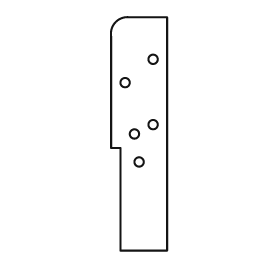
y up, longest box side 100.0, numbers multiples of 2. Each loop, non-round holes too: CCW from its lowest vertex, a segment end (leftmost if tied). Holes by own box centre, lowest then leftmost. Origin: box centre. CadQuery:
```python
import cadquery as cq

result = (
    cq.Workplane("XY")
    .moveTo(-8.0, -50.0)
    .lineTo(12.0, -50.0)
    .lineTo(12.0, 50.0)
    .lineTo(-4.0, 50.0)
    .threePointArc((-10.0, 48.0), (-12.0, 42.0))
    .lineTo(-12.0, -6.0)
    .lineTo(-8.0, -6.0)
    .close()
    .moveTo(0.0, -12.0)
    .circle(2.0)
    .moveTo(-2.0, 0.0)
    .circle(2.0)
    .moveTo(6.0, 4.0)
    .circle(2.0)
    .moveTo(-6.0, 22.0)
    .circle(2.0)
    .moveTo(6.0, 32.0)
    .circle(2.0)
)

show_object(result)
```